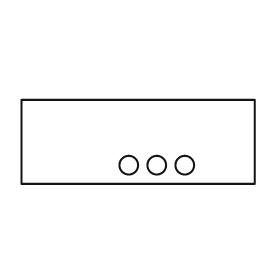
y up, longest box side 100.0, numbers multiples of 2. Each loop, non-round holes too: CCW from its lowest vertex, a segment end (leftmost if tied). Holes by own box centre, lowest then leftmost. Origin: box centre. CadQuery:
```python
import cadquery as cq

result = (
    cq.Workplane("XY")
    .moveTo(-50.0, -18.0)
    .lineTo(50.0, -18.0)
    .lineTo(50.0, 18.0)
    .lineTo(-50.0, 18.0)
    .close()
    .moveTo(-4.0, -10.0)
    .circle(4.0)
    .moveTo(8.0, -10.0)
    .circle(4.0)
    .moveTo(20.0, -10.0)
    .circle(4.0)
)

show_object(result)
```